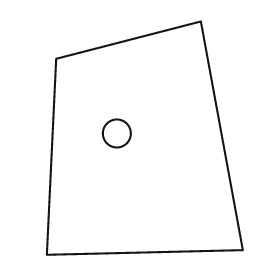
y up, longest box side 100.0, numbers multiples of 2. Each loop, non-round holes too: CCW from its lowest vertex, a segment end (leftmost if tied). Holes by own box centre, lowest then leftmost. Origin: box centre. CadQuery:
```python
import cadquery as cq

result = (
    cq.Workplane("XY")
    .moveTo(-42.0, -50.0)
    .lineTo(42.0, -48.0)
    .lineTo(24.0, 50.0)
    .lineTo(-38.0, 34.0)
    .close()
    .moveTo(-12.0, 2.0)
    .circle(6.0)
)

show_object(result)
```